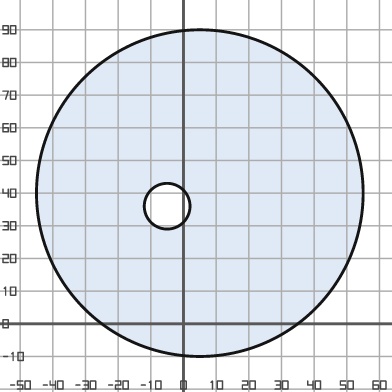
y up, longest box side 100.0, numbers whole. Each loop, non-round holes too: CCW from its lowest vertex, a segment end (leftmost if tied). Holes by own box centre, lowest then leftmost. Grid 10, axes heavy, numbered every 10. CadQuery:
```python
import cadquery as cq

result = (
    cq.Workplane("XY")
    .moveTo(5.0, 40.0)
    .circle(50.0)
    .moveTo(-5.0, 36.0)
    .circle(7.0)
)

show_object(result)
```